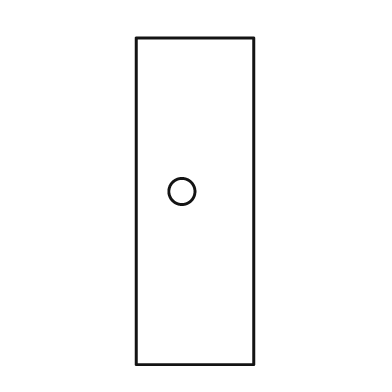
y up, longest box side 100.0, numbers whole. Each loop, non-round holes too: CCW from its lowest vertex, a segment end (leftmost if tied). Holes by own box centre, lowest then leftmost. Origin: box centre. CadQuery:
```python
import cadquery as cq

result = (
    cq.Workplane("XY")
    .moveTo(-18.0, -50.0)
    .lineTo(18.0, -50.0)
    .lineTo(18.0, 50.0)
    .lineTo(-18.0, 50.0)
    .close()
    .moveTo(-4.0, 3.0)
    .circle(4.0)
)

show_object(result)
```